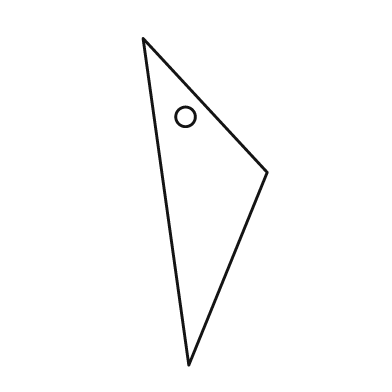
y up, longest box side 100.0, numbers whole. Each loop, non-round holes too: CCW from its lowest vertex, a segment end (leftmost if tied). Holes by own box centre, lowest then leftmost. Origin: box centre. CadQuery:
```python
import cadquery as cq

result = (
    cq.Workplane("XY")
    .moveTo(-5.0, -50.0)
    .lineTo(19.0, 9.0)
    .lineTo(-19.0, 50.0)
    .close()
    .moveTo(-6.0, 26.0)
    .circle(3.0)
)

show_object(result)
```